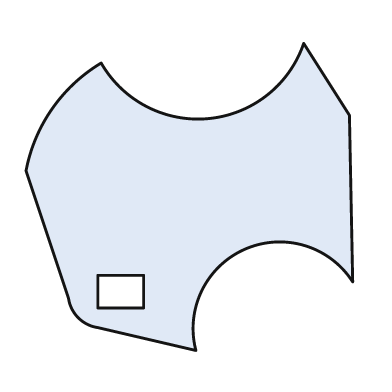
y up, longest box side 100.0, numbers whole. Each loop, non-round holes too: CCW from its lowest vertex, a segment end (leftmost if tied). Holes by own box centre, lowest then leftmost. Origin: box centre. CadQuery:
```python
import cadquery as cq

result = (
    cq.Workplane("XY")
    .moveTo(2.0, -47.0)
    .threePointArc((17.0, -16.0), (50.0, -26.0))
    .lineTo(49.0, 25.0)
    .lineTo(35.0, 47.0)
    .threePointArc((6.0, 24.0), (-27.0, 41.0))
    .threePointArc((-42.0, 27.0), (-50.0, 8.0))
    .lineTo(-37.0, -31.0)
    .threePointArc((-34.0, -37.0), (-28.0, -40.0))
    .close()
    .moveTo(-28.0, -34.0)
    .lineTo(-14.0, -34.0)
    .lineTo(-14.0, -24.0)
    .lineTo(-28.0, -24.0)
    .close()
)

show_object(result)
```